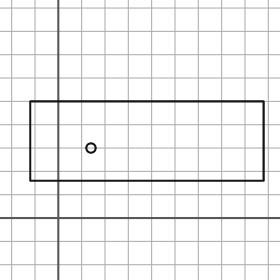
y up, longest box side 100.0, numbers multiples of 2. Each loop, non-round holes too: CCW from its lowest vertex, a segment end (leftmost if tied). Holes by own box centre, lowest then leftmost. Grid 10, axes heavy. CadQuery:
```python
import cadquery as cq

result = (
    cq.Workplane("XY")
    .moveTo(-12.0, 16.0)
    .lineTo(88.0, 16.0)
    .lineTo(88.0, 50.0)
    .lineTo(-12.0, 50.0)
    .close()
    .moveTo(14.0, 30.0)
    .circle(2.0)
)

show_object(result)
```